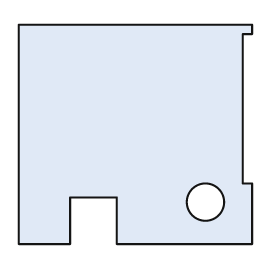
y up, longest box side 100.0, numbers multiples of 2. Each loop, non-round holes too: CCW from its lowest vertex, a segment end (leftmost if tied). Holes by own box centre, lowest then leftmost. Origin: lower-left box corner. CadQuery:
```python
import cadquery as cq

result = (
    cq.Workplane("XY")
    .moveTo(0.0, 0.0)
    .lineTo(22.0, 0.0)
    .lineTo(22.0, 20.0)
    .lineTo(42.0, 20.0)
    .lineTo(42.0, 0.0)
    .lineTo(100.0, 0.0)
    .lineTo(100.0, 26.0)
    .lineTo(96.0, 26.0)
    .lineTo(96.0, 90.0)
    .lineTo(100.0, 90.0)
    .lineTo(100.0, 94.0)
    .lineTo(0.0, 94.0)
    .close()
    .moveTo(80.0, 18.0)
    .circle(8.0)
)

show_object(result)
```